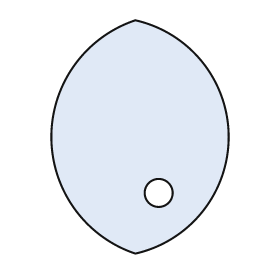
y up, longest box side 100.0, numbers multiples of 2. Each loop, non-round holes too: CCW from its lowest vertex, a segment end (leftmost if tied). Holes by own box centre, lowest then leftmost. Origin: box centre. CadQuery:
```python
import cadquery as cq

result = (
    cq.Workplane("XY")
    .moveTo(-2.0, -50.0)
    .threePointArc((38.0, 0.0), (-2.0, 50.0))
    .threePointArc((-38.0, 0.0), (-2.0, -50.0))
    .close()
    .moveTo(8.0, -24.0)
    .circle(6.0)
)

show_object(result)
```